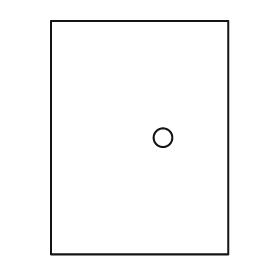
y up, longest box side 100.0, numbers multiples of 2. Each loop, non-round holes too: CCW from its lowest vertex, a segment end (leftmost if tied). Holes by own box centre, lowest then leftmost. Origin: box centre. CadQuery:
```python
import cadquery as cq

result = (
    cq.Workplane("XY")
    .moveTo(-38.0, -50.0)
    .lineTo(38.0, -50.0)
    .lineTo(38.0, 50.0)
    .lineTo(-38.0, 50.0)
    .close()
    .moveTo(10.0, 0.0)
    .circle(4.0)
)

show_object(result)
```